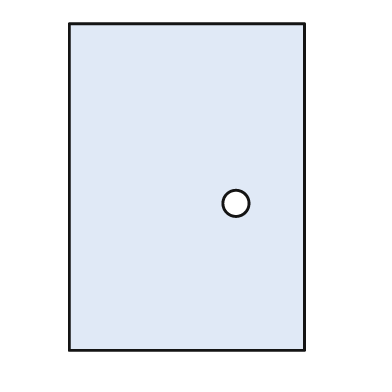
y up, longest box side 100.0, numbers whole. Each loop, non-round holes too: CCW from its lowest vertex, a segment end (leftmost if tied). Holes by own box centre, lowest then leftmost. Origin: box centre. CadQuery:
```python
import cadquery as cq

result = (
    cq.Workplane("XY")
    .moveTo(-36.0, -50.0)
    .lineTo(36.0, -50.0)
    .lineTo(36.0, 50.0)
    .lineTo(-36.0, 50.0)
    .close()
    .moveTo(15.0, -5.0)
    .circle(4.0)
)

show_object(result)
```